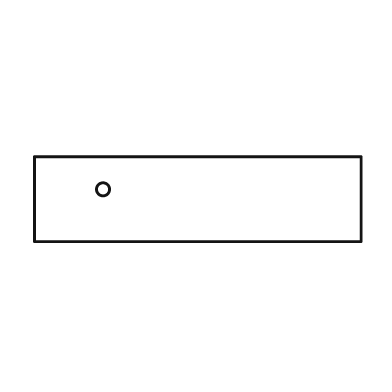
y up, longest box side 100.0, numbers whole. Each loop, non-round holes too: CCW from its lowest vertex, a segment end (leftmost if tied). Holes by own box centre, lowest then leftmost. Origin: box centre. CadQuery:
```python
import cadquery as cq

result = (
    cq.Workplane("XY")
    .moveTo(-50.0, -13.0)
    .lineTo(50.0, -13.0)
    .lineTo(50.0, 13.0)
    .lineTo(-50.0, 13.0)
    .close()
    .moveTo(-29.0, 3.0)
    .circle(2.0)
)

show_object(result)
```